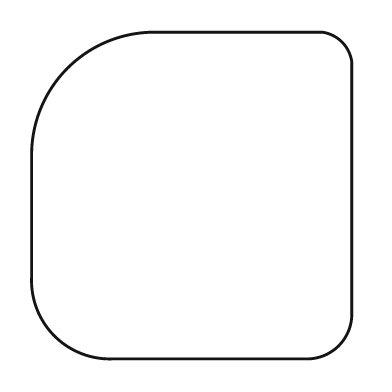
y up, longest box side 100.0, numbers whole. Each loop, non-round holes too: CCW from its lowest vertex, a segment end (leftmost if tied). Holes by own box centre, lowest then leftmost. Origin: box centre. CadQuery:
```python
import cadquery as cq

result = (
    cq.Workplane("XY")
    .moveTo(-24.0, -50.0)
    .lineTo(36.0, -50.0)
    .threePointArc((45.0, -46.0), (49.0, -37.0))
    .lineTo(49.0, 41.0)
    .threePointArc((46.0, 47.0), (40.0, 50.0))
    .lineTo(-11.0, 50.0)
    .threePointArc((-38.0, 39.0), (-49.0, 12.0))
    .lineTo(-49.0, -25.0)
    .threePointArc((-42.0, -43.0), (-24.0, -50.0))
    .close()
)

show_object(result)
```